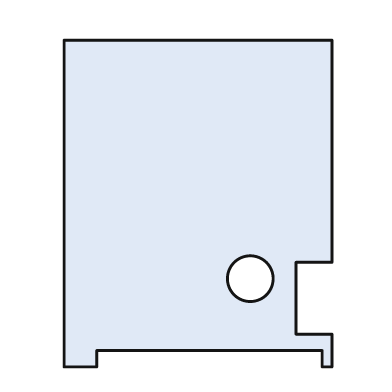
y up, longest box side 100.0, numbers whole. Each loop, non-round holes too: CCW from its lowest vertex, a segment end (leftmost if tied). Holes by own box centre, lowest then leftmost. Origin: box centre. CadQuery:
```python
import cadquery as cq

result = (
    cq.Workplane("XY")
    .moveTo(-41.0, -50.0)
    .lineTo(-31.0, -50.0)
    .lineTo(-31.0, -45.0)
    .lineTo(38.0, -45.0)
    .lineTo(38.0, -50.0)
    .lineTo(41.0, -50.0)
    .lineTo(41.0, -40.0)
    .lineTo(30.0, -40.0)
    .lineTo(30.0, -18.0)
    .lineTo(41.0, -18.0)
    .lineTo(41.0, 50.0)
    .lineTo(-41.0, 50.0)
    .close()
    .moveTo(16.0, -23.0)
    .circle(7.0)
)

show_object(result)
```